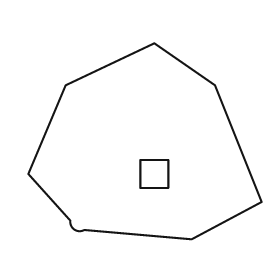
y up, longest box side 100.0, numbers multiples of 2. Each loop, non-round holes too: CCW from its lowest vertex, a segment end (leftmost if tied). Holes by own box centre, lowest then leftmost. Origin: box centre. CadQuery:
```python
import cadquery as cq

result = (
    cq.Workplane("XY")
    .moveTo(20.0, -42.0)
    .lineTo(50.0, -26.0)
    .lineTo(30.0, 24.0)
    .lineTo(4.0, 42.0)
    .lineTo(-34.0, 24.0)
    .lineTo(-50.0, -14.0)
    .lineTo(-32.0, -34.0)
    .threePointArc((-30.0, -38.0), (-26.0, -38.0))
    .close()
    .moveTo(-2.0, -20.0)
    .lineTo(10.0, -20.0)
    .lineTo(10.0, -8.0)
    .lineTo(-2.0, -8.0)
    .close()
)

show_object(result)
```